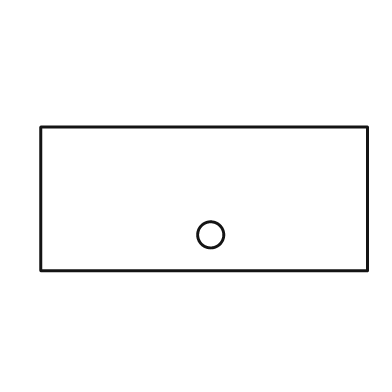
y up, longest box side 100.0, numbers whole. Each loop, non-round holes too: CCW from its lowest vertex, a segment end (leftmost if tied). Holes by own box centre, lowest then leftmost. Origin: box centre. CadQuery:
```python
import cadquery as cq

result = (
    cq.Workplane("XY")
    .moveTo(-50.0, -22.0)
    .lineTo(50.0, -22.0)
    .lineTo(50.0, 22.0)
    .lineTo(-50.0, 22.0)
    .close()
    .moveTo(2.0, -11.0)
    .circle(4.0)
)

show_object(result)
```